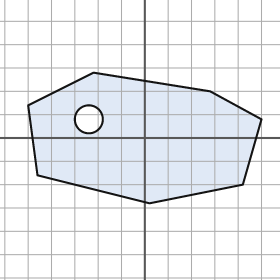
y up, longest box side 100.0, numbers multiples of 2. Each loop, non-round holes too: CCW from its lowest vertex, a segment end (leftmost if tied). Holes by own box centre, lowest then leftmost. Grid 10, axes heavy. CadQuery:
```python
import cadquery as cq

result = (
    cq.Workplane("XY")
    .moveTo(2.0, -28.0)
    .lineTo(42.0, -20.0)
    .lineTo(50.0, 8.0)
    .lineTo(28.0, 20.0)
    .lineTo(-22.0, 28.0)
    .lineTo(-50.0, 14.0)
    .lineTo(-46.0, -16.0)
    .close()
    .moveTo(-24.0, 8.0)
    .circle(6.0)
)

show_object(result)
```